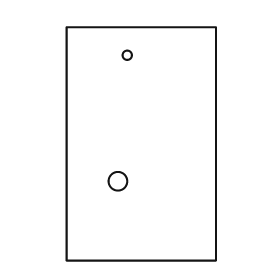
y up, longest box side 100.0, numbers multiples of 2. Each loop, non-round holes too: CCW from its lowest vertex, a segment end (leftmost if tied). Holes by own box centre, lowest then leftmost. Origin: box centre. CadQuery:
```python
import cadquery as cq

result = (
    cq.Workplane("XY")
    .moveTo(-32.0, -50.0)
    .lineTo(32.0, -50.0)
    .lineTo(32.0, 50.0)
    .lineTo(-32.0, 50.0)
    .close()
    .moveTo(-10.0, -16.0)
    .circle(4.0)
    .moveTo(-6.0, 38.0)
    .circle(2.0)
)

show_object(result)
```